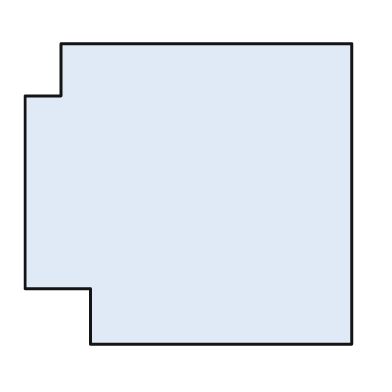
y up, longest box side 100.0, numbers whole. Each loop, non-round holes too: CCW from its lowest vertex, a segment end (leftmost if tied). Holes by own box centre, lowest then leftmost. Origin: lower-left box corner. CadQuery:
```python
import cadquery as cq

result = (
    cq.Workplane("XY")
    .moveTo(20.0, 0.0)
    .lineTo(100.0, 0.0)
    .lineTo(100.0, 92.0)
    .lineTo(11.0, 92.0)
    .lineTo(11.0, 76.0)
    .lineTo(0.0, 76.0)
    .lineTo(0.0, 17.0)
    .lineTo(20.0, 17.0)
    .close()
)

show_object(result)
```